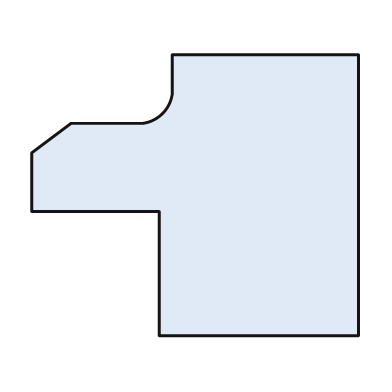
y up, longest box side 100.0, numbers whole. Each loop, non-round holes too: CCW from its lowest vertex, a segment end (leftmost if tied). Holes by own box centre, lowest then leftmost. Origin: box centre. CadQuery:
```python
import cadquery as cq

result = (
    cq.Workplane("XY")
    .moveTo(-11.0, -43.0)
    .lineTo(50.0, -43.0)
    .lineTo(50.0, 43.0)
    .lineTo(-7.0, 43.0)
    .lineTo(-7.0, 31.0)
    .threePointArc((-10.0, 25.0), (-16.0, 22.0))
    .lineTo(-38.0, 22.0)
    .lineTo(-50.0, 13.0)
    .lineTo(-50.0, -5.0)
    .lineTo(-11.0, -5.0)
    .close()
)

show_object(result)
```